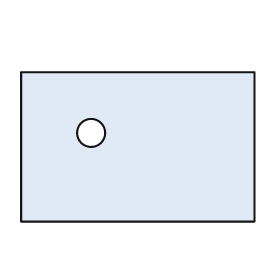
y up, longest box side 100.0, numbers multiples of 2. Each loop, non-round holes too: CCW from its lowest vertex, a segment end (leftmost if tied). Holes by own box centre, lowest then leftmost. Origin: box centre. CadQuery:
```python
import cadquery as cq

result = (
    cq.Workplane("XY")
    .moveTo(-50.0, -32.0)
    .lineTo(50.0, -32.0)
    .lineTo(50.0, 32.0)
    .lineTo(-50.0, 32.0)
    .close()
    .moveTo(-20.0, 6.0)
    .circle(6.0)
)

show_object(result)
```